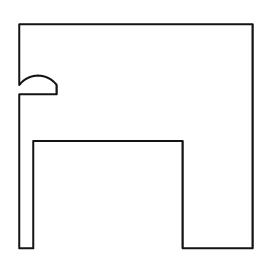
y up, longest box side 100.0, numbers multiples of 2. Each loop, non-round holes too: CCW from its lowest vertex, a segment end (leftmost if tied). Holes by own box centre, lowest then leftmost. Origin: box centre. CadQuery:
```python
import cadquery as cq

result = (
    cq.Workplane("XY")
    .moveTo(-50.0, -48.0)
    .lineTo(-44.0, -48.0)
    .lineTo(-44.0, -2.0)
    .lineTo(20.0, -2.0)
    .lineTo(20.0, -48.0)
    .lineTo(50.0, -48.0)
    .lineTo(50.0, 48.0)
    .lineTo(-50.0, 48.0)
    .lineTo(-50.0, 22.0)
    .threePointArc((-42.0, 26.0), (-34.0, 22.0))
    .lineTo(-34.0, 18.0)
    .lineTo(-50.0, 18.0)
    .close()
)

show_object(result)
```